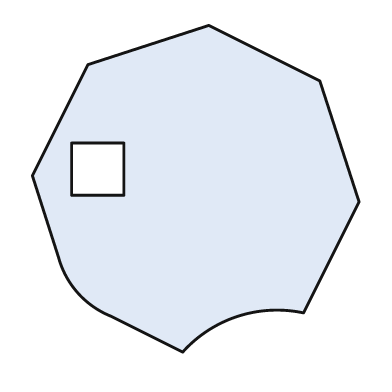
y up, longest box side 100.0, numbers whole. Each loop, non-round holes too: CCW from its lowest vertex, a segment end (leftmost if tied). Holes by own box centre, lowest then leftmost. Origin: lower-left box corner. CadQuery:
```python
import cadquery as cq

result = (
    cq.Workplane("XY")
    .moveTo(46.0, 0.0)
    .threePointArc((63.0, 11.0), (83.0, 12.0))
    .lineTo(100.0, 46.0)
    .lineTo(88.0, 83.0)
    .lineTo(54.0, 100.0)
    .lineTo(17.0, 88.0)
    .lineTo(0.0, 54.0)
    .lineTo(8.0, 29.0)
    .threePointArc((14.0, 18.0), (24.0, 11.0))
    .close()
    .moveTo(12.0, 48.0)
    .lineTo(28.0, 48.0)
    .lineTo(28.0, 64.0)
    .lineTo(12.0, 64.0)
    .close()
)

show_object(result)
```